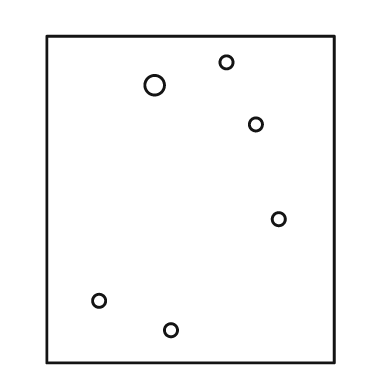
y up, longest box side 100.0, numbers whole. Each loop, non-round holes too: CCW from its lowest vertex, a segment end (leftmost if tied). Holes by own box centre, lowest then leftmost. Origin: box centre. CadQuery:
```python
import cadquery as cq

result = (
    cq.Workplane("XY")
    .moveTo(-44.0, -50.0)
    .lineTo(44.0, -50.0)
    .lineTo(44.0, 50.0)
    .lineTo(-44.0, 50.0)
    .close()
    .moveTo(-6.0, -40.0)
    .circle(2.0)
    .moveTo(-28.0, -31.0)
    .circle(2.0)
    .moveTo(27.0, -6.0)
    .circle(2.0)
    .moveTo(20.0, 23.0)
    .circle(2.0)
    .moveTo(-11.0, 35.0)
    .circle(3.0)
    .moveTo(11.0, 42.0)
    .circle(2.0)
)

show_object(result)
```